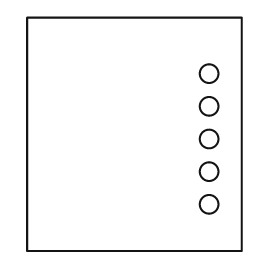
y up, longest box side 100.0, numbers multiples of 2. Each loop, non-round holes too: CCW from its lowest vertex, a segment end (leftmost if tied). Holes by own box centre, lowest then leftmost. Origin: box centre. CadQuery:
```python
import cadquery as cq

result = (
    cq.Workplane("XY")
    .moveTo(-46.0, -50.0)
    .lineTo(46.0, -50.0)
    .lineTo(46.0, 50.0)
    .lineTo(-46.0, 50.0)
    .close()
    .moveTo(32.0, -30.0)
    .circle(4.0)
    .moveTo(32.0, -16.0)
    .circle(4.0)
    .moveTo(32.0, -2.0)
    .circle(4.0)
    .moveTo(32.0, 12.0)
    .circle(4.0)
    .moveTo(32.0, 26.0)
    .circle(4.0)
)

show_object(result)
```